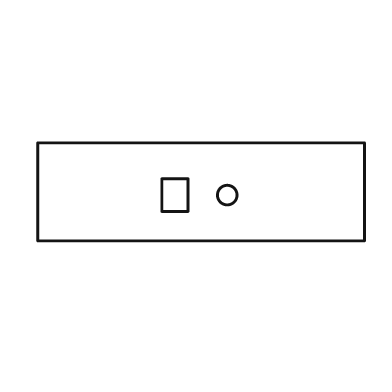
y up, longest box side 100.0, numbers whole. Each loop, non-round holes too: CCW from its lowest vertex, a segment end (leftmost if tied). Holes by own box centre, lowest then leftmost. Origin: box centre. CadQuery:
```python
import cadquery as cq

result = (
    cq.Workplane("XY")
    .moveTo(-50.0, -15.0)
    .lineTo(50.0, -15.0)
    .lineTo(50.0, 15.0)
    .lineTo(-50.0, 15.0)
    .close()
    .moveTo(-12.0, -6.0)
    .lineTo(-4.0, -6.0)
    .lineTo(-4.0, 4.0)
    .lineTo(-12.0, 4.0)
    .close()
    .moveTo(8.0, -1.0)
    .circle(3.0)
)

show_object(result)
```